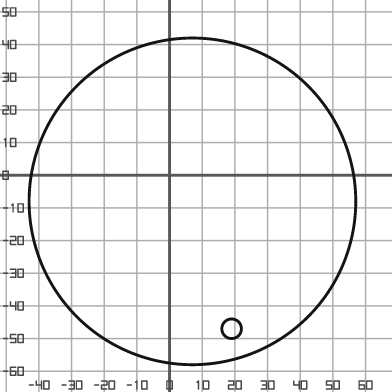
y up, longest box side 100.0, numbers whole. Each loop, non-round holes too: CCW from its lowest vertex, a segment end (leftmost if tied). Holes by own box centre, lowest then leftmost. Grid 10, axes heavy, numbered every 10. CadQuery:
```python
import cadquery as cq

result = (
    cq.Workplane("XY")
    .moveTo(7.0, -8.0)
    .circle(50.0)
    .moveTo(19.0, -47.0)
    .circle(3.0)
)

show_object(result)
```